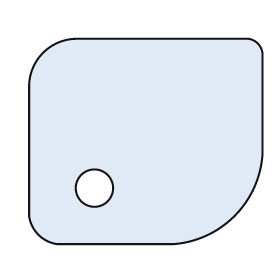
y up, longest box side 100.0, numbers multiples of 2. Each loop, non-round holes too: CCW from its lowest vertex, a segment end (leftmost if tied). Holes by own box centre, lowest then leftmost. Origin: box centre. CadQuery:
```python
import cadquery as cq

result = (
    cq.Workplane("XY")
    .moveTo(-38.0, -44.0)
    .lineTo(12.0, -44.0)
    .threePointArc((38.0, -32.0), (50.0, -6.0))
    .lineTo(50.0, 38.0)
    .threePointArc((48.0, 42.0), (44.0, 44.0))
    .lineTo(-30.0, 44.0)
    .threePointArc((-44.0, 38.0), (-50.0, 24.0))
    .lineTo(-50.0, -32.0)
    .threePointArc((-46.0, -40.0), (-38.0, -44.0))
    .close()
    .moveTo(-22.0, -20.0)
    .circle(8.0)
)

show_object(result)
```